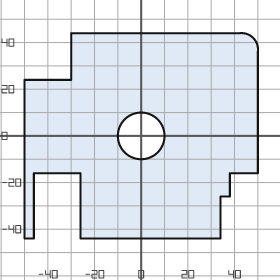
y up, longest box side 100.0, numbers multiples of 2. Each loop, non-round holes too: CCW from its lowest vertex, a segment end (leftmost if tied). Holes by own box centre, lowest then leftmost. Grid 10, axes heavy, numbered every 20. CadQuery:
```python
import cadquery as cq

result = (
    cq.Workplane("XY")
    .moveTo(-50.0, -44.0)
    .lineTo(-46.0, -44.0)
    .lineTo(-46.0, -16.0)
    .lineTo(-26.0, -16.0)
    .lineTo(-26.0, -44.0)
    .lineTo(34.0, -44.0)
    .lineTo(34.0, -26.0)
    .lineTo(38.0, -26.0)
    .lineTo(38.0, -16.0)
    .lineTo(50.0, -16.0)
    .lineTo(50.0, 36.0)
    .threePointArc((48.0, 42.0), (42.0, 44.0))
    .lineTo(-30.0, 44.0)
    .lineTo(-30.0, 24.0)
    .lineTo(-50.0, 24.0)
    .close()
    .moveTo(0.0, 0.0)
    .circle(10.0)
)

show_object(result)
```